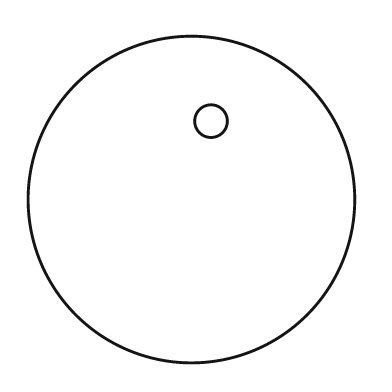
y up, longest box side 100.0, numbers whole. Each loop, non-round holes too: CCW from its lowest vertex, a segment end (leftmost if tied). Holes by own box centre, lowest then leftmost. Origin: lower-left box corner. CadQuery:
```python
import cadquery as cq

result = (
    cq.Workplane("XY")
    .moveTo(50.0, 50.0)
    .circle(50.0)
    .moveTo(56.0, 74.0)
    .circle(5.0)
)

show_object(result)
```